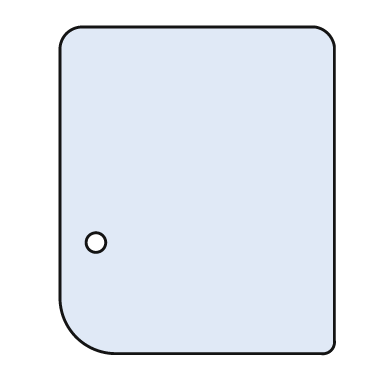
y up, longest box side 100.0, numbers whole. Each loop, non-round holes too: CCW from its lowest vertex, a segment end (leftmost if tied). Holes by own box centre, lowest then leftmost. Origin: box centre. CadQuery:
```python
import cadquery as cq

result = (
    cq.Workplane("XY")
    .moveTo(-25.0, -50.0)
    .lineTo(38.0, -50.0)
    .threePointArc((41.0, -49.0), (42.0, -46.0))
    .lineTo(42.0, 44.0)
    .threePointArc((40.0, 48.0), (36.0, 50.0))
    .lineTo(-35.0, 50.0)
    .threePointArc((-40.0, 48.0), (-42.0, 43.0))
    .lineTo(-42.0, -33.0)
    .threePointArc((-37.0, -45.0), (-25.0, -50.0))
    .close()
    .moveTo(-31.0, -16.0)
    .circle(3.0)
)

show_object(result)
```